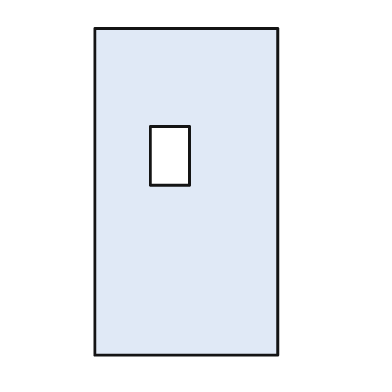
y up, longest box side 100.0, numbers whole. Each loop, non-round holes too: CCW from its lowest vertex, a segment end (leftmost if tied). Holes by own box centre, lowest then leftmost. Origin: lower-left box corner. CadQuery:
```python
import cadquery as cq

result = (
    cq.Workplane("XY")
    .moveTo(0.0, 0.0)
    .lineTo(56.0, 0.0)
    .lineTo(56.0, 100.0)
    .lineTo(0.0, 100.0)
    .close()
    .moveTo(17.0, 52.0)
    .lineTo(29.0, 52.0)
    .lineTo(29.0, 70.0)
    .lineTo(17.0, 70.0)
    .close()
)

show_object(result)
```